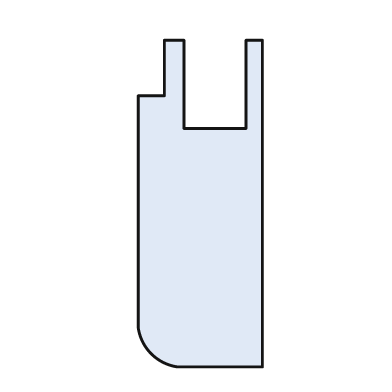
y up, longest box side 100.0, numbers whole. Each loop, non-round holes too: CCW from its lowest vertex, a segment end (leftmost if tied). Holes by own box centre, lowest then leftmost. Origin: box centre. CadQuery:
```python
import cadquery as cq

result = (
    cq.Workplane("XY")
    .moveTo(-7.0, -50.0)
    .lineTo(19.0, -50.0)
    .lineTo(19.0, 50.0)
    .lineTo(14.0, 50.0)
    .lineTo(14.0, 23.0)
    .lineTo(-5.0, 23.0)
    .lineTo(-5.0, 50.0)
    .lineTo(-11.0, 50.0)
    .lineTo(-11.0, 33.0)
    .lineTo(-19.0, 33.0)
    .lineTo(-19.0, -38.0)
    .threePointArc((-15.0, -46.0), (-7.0, -50.0))
    .close()
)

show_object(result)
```